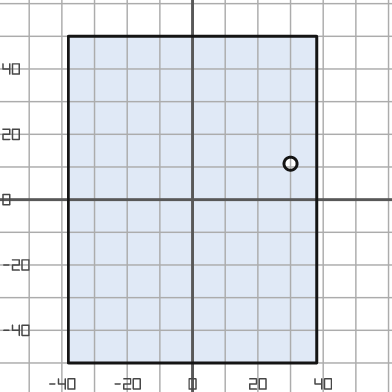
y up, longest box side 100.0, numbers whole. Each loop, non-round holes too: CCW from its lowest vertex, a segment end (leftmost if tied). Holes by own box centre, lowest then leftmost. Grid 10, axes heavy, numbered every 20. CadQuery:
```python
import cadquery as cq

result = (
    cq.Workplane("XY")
    .moveTo(-38.0, -50.0)
    .lineTo(38.0, -50.0)
    .lineTo(38.0, 50.0)
    .lineTo(-38.0, 50.0)
    .close()
    .moveTo(30.0, 11.0)
    .circle(2.0)
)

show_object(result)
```